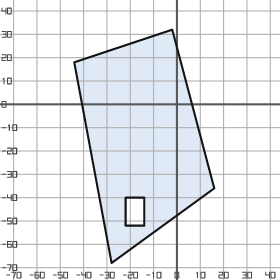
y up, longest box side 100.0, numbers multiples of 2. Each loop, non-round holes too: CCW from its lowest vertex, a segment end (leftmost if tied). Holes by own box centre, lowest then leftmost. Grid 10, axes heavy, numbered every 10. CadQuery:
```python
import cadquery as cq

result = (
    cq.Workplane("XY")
    .moveTo(-28.0, -68.0)
    .lineTo(16.0, -36.0)
    .lineTo(-2.0, 32.0)
    .lineTo(-44.0, 18.0)
    .close()
    .moveTo(-22.0, -52.0)
    .lineTo(-14.0, -52.0)
    .lineTo(-14.0, -40.0)
    .lineTo(-22.0, -40.0)
    .close()
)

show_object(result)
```